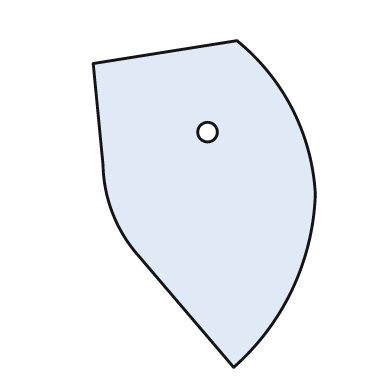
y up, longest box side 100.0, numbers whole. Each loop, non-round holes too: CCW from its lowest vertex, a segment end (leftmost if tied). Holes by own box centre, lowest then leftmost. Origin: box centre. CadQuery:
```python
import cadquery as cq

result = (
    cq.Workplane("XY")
    .moveTo(9.0, -50.0)
    .threePointArc((27.0, -26.0), (34.0, 3.0))
    .threePointArc((27.0, 29.0), (10.0, 50.0))
    .lineTo(-34.0, 43.0)
    .lineTo(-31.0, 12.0)
    .threePointArc((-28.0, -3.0), (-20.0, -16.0))
    .close()
    .moveTo(1.0, 22.0)
    .circle(3.0)
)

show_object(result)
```